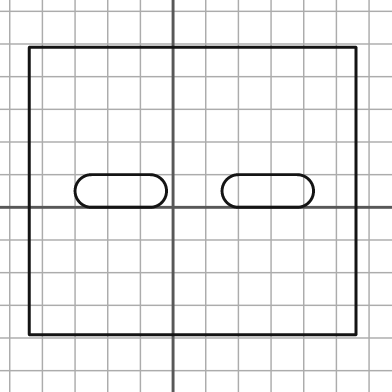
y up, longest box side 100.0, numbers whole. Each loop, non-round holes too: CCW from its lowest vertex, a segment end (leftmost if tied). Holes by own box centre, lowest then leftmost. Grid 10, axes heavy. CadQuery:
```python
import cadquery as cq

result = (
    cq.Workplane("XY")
    .moveTo(-44.0, -39.0)
    .lineTo(56.0, -39.0)
    .lineTo(56.0, 49.0)
    .lineTo(-44.0, 49.0)
    .close()
    .moveTo(-25.0, 0.0)
    .lineTo(-7.0, 0.0)
    .threePointArc((-2.0, 5.0), (-7.0, 10.0))
    .lineTo(-25.0, 10.0)
    .threePointArc((-30.0, 5.0), (-25.0, 0.0))
    .close()
    .moveTo(20.0, 0.0)
    .lineTo(38.0, 0.0)
    .threePointArc((43.0, 5.0), (38.0, 10.0))
    .lineTo(20.0, 10.0)
    .threePointArc((15.0, 5.0), (20.0, 0.0))
    .close()
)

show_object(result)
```